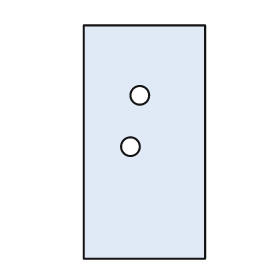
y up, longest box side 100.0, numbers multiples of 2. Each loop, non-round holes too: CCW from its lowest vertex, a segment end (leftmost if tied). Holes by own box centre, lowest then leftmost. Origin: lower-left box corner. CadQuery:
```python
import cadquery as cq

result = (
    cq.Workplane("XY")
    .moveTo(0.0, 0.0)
    .lineTo(52.0, 0.0)
    .lineTo(52.0, 100.0)
    .lineTo(0.0, 100.0)
    .close()
    .moveTo(20.0, 48.0)
    .circle(4.0)
    .moveTo(24.0, 70.0)
    .circle(4.0)
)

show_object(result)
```